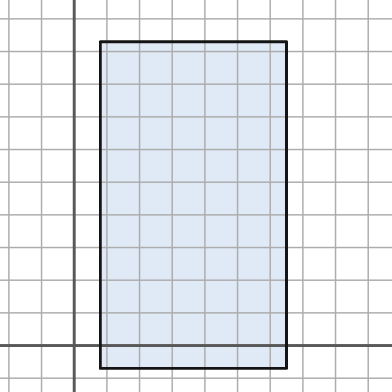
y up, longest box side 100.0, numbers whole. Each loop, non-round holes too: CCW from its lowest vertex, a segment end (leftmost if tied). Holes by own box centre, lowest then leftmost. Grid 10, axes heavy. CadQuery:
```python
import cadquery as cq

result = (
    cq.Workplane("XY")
    .moveTo(8.0, -7.0)
    .lineTo(65.0, -7.0)
    .lineTo(65.0, 93.0)
    .lineTo(8.0, 93.0)
    .close()
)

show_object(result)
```